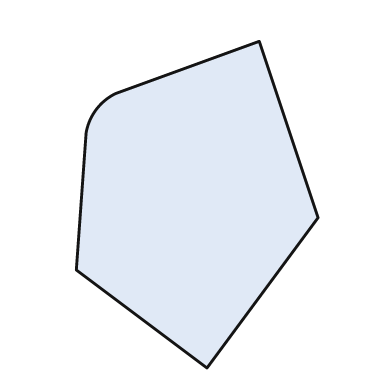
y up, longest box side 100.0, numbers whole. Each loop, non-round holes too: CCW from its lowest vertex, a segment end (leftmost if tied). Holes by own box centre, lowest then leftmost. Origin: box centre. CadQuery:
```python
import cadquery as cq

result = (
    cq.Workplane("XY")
    .moveTo(3.0, -50.0)
    .lineTo(37.0, -4.0)
    .lineTo(19.0, 50.0)
    .lineTo(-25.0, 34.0)
    .threePointArc((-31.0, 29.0), (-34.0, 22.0))
    .lineTo(-37.0, -20.0)
    .close()
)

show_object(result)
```